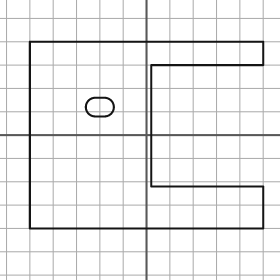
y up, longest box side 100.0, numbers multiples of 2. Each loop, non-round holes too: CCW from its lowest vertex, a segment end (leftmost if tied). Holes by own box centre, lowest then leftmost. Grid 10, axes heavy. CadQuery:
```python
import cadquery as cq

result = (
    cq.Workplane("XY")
    .moveTo(-50.0, -40.0)
    .lineTo(50.0, -40.0)
    .lineTo(50.0, -22.0)
    .lineTo(2.0, -22.0)
    .lineTo(2.0, 30.0)
    .lineTo(50.0, 30.0)
    .lineTo(50.0, 40.0)
    .lineTo(-50.0, 40.0)
    .close()
    .moveTo(-22.0, 8.0)
    .lineTo(-18.0, 8.0)
    .threePointArc((-14.0, 12.0), (-18.0, 16.0))
    .lineTo(-22.0, 16.0)
    .threePointArc((-26.0, 12.0), (-22.0, 8.0))
    .close()
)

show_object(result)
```